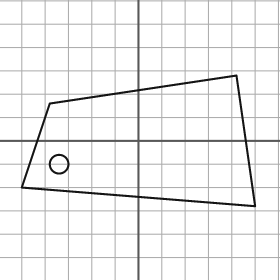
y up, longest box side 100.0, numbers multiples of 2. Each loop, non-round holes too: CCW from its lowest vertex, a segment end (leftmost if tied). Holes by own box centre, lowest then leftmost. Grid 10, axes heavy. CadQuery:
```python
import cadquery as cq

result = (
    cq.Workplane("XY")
    .moveTo(50.0, -28.0)
    .lineTo(42.0, 28.0)
    .lineTo(-38.0, 16.0)
    .lineTo(-50.0, -20.0)
    .close()
    .moveTo(-34.0, -10.0)
    .circle(4.0)
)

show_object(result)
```